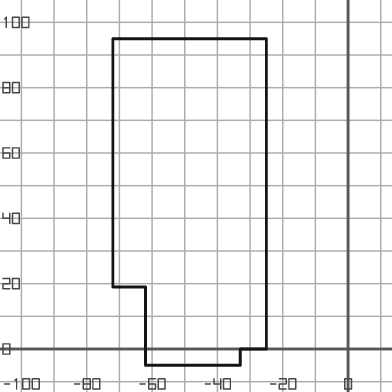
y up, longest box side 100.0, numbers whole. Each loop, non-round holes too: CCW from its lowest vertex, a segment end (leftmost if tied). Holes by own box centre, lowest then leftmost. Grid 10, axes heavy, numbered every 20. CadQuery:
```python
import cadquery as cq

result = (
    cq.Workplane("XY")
    .moveTo(-62.0, -5.0)
    .lineTo(-33.0, -5.0)
    .lineTo(-33.0, 0.0)
    .lineTo(-25.0, 0.0)
    .lineTo(-25.0, 95.0)
    .lineTo(-72.0, 95.0)
    .lineTo(-72.0, 19.0)
    .lineTo(-62.0, 19.0)
    .close()
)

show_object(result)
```